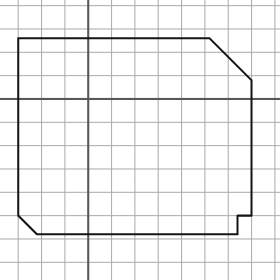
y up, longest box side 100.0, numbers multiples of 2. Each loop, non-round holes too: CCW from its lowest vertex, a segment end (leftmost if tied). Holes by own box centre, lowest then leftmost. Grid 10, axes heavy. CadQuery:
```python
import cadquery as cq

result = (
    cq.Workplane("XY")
    .moveTo(-22.0, -58.0)
    .lineTo(64.0, -58.0)
    .lineTo(64.0, -50.0)
    .lineTo(70.0, -50.0)
    .lineTo(70.0, 8.0)
    .lineTo(52.0, 26.0)
    .lineTo(-30.0, 26.0)
    .lineTo(-30.0, -50.0)
    .close()
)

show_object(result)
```